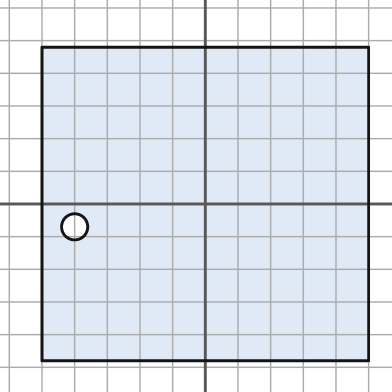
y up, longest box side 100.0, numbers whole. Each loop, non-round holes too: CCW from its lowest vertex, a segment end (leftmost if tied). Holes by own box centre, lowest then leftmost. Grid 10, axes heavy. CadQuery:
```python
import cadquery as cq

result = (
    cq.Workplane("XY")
    .moveTo(-50.0, -48.0)
    .lineTo(50.0, -48.0)
    .lineTo(50.0, 48.0)
    .lineTo(-50.0, 48.0)
    .close()
    .moveTo(-40.0, -7.0)
    .circle(4.0)
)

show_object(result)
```